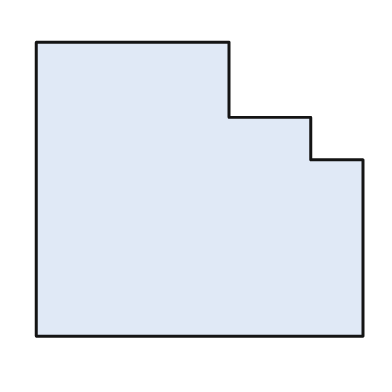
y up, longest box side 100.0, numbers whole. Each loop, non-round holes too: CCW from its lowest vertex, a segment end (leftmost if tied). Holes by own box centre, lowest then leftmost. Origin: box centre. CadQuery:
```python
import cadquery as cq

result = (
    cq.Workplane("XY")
    .moveTo(-50.0, -45.0)
    .lineTo(50.0, -45.0)
    .lineTo(50.0, 9.0)
    .lineTo(34.0, 9.0)
    .lineTo(34.0, 22.0)
    .lineTo(9.0, 22.0)
    .lineTo(9.0, 45.0)
    .lineTo(-50.0, 45.0)
    .close()
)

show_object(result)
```